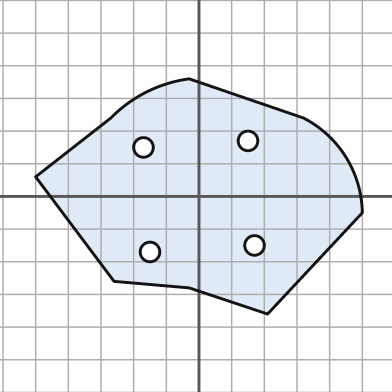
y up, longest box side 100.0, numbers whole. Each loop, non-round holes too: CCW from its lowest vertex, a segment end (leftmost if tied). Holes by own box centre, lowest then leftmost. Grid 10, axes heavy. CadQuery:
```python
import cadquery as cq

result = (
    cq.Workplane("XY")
    .moveTo(21.0, -36.0)
    .lineTo(50.0, -5.0)
    .threePointArc((45.0, 12.0), (32.0, 24.0))
    .lineTo(-3.0, 36.0)
    .threePointArc((-16.0, 32.0), (-27.0, 24.0))
    .lineTo(-50.0, 6.0)
    .lineTo(-26.0, -26.0)
    .lineTo(-3.0, -28.0)
    .close()
    .moveTo(-15.0, -17.0)
    .circle(3.0)
    .moveTo(17.0, -15.0)
    .circle(3.0)
    .moveTo(-17.0, 15.0)
    .circle(3.0)
    .moveTo(15.0, 17.0)
    .circle(3.0)
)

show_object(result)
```